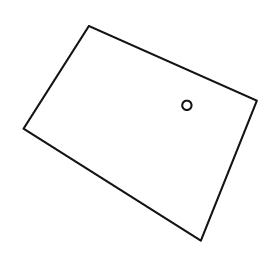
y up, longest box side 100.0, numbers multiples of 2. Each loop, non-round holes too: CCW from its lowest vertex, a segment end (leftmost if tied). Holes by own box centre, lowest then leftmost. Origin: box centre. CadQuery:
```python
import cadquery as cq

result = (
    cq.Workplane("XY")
    .moveTo(26.0, -46.0)
    .lineTo(50.0, 14.0)
    .lineTo(-22.0, 46.0)
    .lineTo(-50.0, 2.0)
    .close()
    .moveTo(20.0, 12.0)
    .circle(2.0)
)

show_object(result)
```